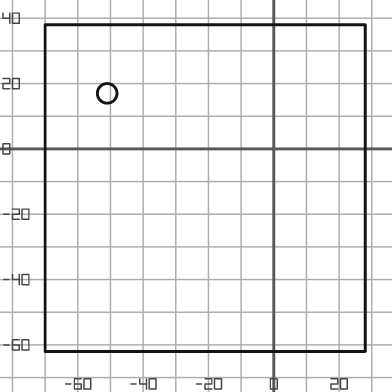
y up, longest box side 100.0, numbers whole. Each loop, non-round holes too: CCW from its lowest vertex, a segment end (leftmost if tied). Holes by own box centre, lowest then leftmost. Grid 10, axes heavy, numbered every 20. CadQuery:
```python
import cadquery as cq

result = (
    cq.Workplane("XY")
    .moveTo(-70.0, -62.0)
    .lineTo(28.0, -62.0)
    .lineTo(28.0, 38.0)
    .lineTo(-70.0, 38.0)
    .close()
    .moveTo(-51.0, 17.0)
    .circle(3.0)
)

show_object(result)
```